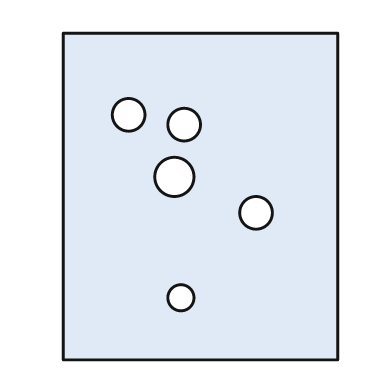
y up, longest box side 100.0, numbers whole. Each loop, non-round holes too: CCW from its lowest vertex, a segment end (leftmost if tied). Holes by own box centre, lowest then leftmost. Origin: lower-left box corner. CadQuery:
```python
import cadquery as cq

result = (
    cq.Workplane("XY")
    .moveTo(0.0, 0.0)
    .lineTo(84.0, 0.0)
    .lineTo(84.0, 100.0)
    .lineTo(0.0, 100.0)
    .close()
    .moveTo(36.0, 19.0)
    .circle(4.0)
    .moveTo(59.0, 45.0)
    .circle(5.0)
    .moveTo(34.0, 56.0)
    .circle(6.0)
    .moveTo(37.0, 72.0)
    .circle(5.0)
    .moveTo(20.0, 75.0)
    .circle(5.0)
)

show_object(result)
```